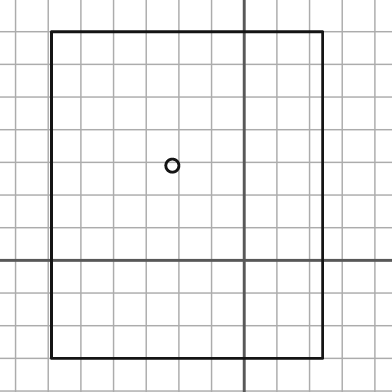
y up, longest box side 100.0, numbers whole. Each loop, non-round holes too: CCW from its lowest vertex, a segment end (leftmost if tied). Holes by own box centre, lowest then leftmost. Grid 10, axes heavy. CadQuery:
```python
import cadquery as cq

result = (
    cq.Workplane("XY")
    .moveTo(-59.0, -30.0)
    .lineTo(24.0, -30.0)
    .lineTo(24.0, 70.0)
    .lineTo(-59.0, 70.0)
    .close()
    .moveTo(-22.0, 29.0)
    .circle(2.0)
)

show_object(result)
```